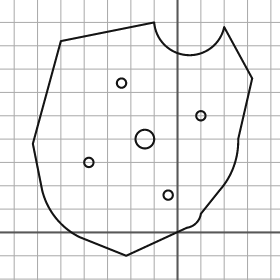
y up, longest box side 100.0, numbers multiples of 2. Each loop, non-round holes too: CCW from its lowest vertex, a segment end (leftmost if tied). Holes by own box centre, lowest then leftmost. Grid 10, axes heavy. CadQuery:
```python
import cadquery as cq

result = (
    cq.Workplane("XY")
    .moveTo(-22.0, -10.0)
    .lineTo(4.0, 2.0)
    .threePointArc((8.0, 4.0), (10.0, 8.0))
    .lineTo(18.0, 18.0)
    .threePointArc((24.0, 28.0), (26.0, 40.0))
    .lineTo(32.0, 66.0)
    .lineTo(20.0, 88.0)
    .threePointArc((4.0, 76.0), (-10.0, 90.0))
    .lineTo(-50.0, 82.0)
    .lineTo(-62.0, 38.0)
    .lineTo(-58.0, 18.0)
    .threePointArc((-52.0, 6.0), (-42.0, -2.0))
    .close()
    .moveTo(-4.0, 16.0)
    .circle(2.0)
    .moveTo(-38.0, 30.0)
    .circle(2.0)
    .moveTo(-14.0, 40.0)
    .circle(4.0)
    .moveTo(10.0, 50.0)
    .circle(2.0)
    .moveTo(-24.0, 64.0)
    .circle(2.0)
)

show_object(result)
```